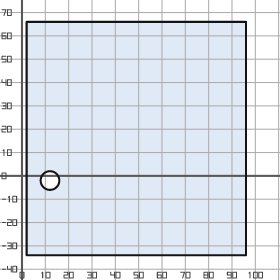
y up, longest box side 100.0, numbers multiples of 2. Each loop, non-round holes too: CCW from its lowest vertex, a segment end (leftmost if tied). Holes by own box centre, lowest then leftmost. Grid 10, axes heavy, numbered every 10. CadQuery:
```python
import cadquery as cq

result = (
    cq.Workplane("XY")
    .moveTo(2.0, -34.0)
    .lineTo(96.0, -34.0)
    .lineTo(96.0, 66.0)
    .lineTo(2.0, 66.0)
    .close()
    .moveTo(12.0, -2.0)
    .circle(4.0)
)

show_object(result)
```